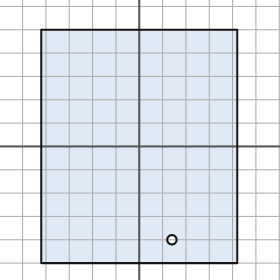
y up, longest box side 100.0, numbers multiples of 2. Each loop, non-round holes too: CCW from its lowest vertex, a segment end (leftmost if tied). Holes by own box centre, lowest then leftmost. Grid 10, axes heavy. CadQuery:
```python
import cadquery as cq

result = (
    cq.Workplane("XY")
    .moveTo(-42.0, -50.0)
    .lineTo(42.0, -50.0)
    .lineTo(42.0, 50.0)
    .lineTo(-42.0, 50.0)
    .close()
    .moveTo(14.0, -40.0)
    .circle(2.0)
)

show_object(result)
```